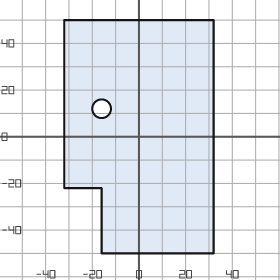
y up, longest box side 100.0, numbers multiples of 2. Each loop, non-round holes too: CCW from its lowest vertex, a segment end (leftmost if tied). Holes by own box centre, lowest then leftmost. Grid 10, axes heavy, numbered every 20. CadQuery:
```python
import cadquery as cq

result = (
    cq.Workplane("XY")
    .moveTo(-16.0, -50.0)
    .lineTo(32.0, -50.0)
    .lineTo(32.0, 50.0)
    .lineTo(-32.0, 50.0)
    .lineTo(-32.0, -22.0)
    .lineTo(-16.0, -22.0)
    .close()
    .moveTo(-16.0, 12.0)
    .circle(4.0)
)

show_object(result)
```